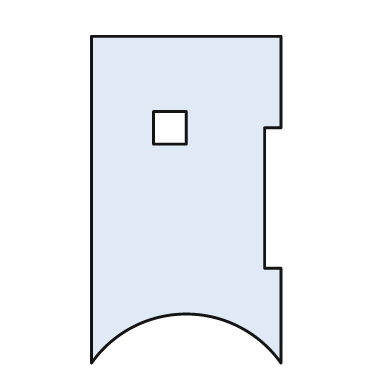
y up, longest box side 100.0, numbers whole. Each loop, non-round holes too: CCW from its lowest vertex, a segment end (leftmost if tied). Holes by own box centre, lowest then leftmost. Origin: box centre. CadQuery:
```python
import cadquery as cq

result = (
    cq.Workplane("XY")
    .moveTo(-29.0, -50.0)
    .threePointArc((0.0, -35.0), (29.0, -50.0))
    .lineTo(29.0, -21.0)
    .lineTo(24.0, -21.0)
    .lineTo(24.0, 22.0)
    .lineTo(29.0, 22.0)
    .lineTo(29.0, 50.0)
    .lineTo(-29.0, 50.0)
    .close()
    .moveTo(-10.0, 17.0)
    .lineTo(0.0, 17.0)
    .lineTo(0.0, 27.0)
    .lineTo(-10.0, 27.0)
    .close()
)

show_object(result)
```